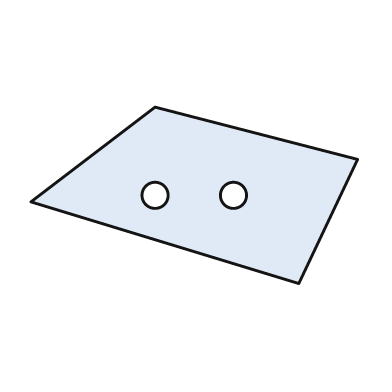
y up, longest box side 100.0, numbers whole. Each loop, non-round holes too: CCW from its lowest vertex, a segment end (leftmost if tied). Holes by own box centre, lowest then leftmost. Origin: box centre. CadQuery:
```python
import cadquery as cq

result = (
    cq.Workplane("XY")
    .moveTo(32.0, -27.0)
    .lineTo(50.0, 11.0)
    .lineTo(-12.0, 27.0)
    .lineTo(-50.0, -2.0)
    .close()
    .moveTo(-12.0, 0.0)
    .circle(4.0)
    .moveTo(12.0, 0.0)
    .circle(4.0)
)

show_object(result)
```